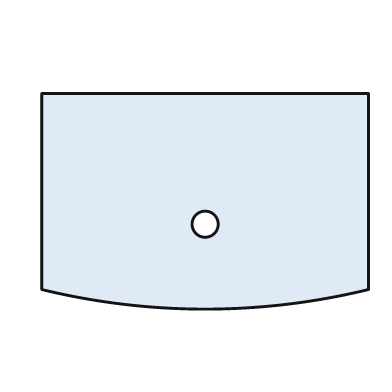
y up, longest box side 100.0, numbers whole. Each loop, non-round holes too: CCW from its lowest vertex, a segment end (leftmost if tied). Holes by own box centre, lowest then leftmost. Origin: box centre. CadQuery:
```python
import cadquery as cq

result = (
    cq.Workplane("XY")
    .moveTo(-50.0, -27.0)
    .threePointArc((0.0, -33.0), (50.0, -27.0))
    .lineTo(50.0, 33.0)
    .lineTo(-50.0, 33.0)
    .close()
    .moveTo(0.0, -7.0)
    .circle(4.0)
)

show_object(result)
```